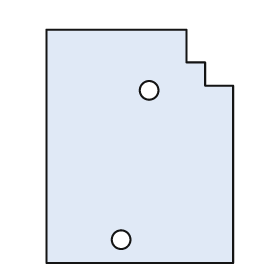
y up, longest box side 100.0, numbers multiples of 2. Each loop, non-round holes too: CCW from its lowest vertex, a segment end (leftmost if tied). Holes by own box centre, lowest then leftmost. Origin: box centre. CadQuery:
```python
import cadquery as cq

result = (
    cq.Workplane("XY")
    .moveTo(-40.0, -50.0)
    .lineTo(40.0, -50.0)
    .lineTo(40.0, 26.0)
    .lineTo(28.0, 26.0)
    .lineTo(28.0, 36.0)
    .lineTo(20.0, 36.0)
    .lineTo(20.0, 50.0)
    .lineTo(-40.0, 50.0)
    .close()
    .moveTo(-8.0, -40.0)
    .circle(4.0)
    .moveTo(4.0, 24.0)
    .circle(4.0)
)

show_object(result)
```